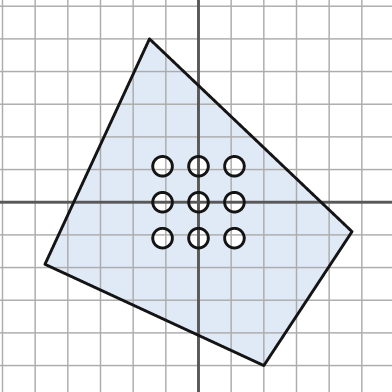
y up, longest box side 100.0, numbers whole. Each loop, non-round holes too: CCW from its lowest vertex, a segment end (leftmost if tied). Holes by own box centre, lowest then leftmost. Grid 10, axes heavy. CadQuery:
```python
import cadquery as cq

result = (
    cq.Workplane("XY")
    .moveTo(20.0, -50.0)
    .lineTo(47.0, -9.0)
    .lineTo(-15.0, 50.0)
    .lineTo(-47.0, -19.0)
    .close()
    .moveTo(-11.0, -11.0)
    .circle(3.0)
    .moveTo(0.0, -11.0)
    .circle(3.0)
    .moveTo(11.0, -11.0)
    .circle(3.0)
    .moveTo(-11.0, 0.0)
    .circle(3.0)
    .moveTo(0.0, 0.0)
    .circle(3.0)
    .moveTo(11.0, 0.0)
    .circle(3.0)
    .moveTo(-11.0, 11.0)
    .circle(3.0)
    .moveTo(0.0, 11.0)
    .circle(3.0)
    .moveTo(11.0, 11.0)
    .circle(3.0)
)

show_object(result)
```